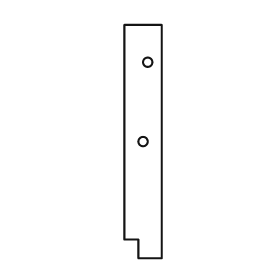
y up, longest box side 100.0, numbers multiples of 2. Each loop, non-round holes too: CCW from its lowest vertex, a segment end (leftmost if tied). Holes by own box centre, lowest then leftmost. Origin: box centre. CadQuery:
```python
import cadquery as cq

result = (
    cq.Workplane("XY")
    .moveTo(-2.0, -50.0)
    .lineTo(8.0, -50.0)
    .lineTo(8.0, 50.0)
    .lineTo(-8.0, 50.0)
    .lineTo(-8.0, -42.0)
    .lineTo(-2.0, -42.0)
    .close()
    .moveTo(0.0, 0.0)
    .circle(2.0)
    .moveTo(2.0, 34.0)
    .circle(2.0)
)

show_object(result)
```